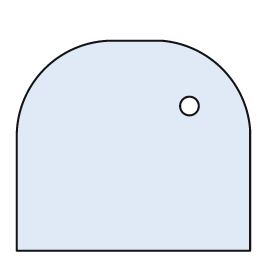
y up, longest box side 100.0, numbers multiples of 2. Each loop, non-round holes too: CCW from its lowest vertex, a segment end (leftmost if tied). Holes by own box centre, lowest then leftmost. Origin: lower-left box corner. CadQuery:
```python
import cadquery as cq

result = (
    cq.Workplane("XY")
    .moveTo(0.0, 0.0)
    .lineTo(100.0, 0.0)
    .lineTo(100.0, 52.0)
    .threePointArc((88.0, 78.0), (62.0, 90.0))
    .lineTo(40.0, 90.0)
    .threePointArc((12.0, 78.0), (0.0, 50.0))
    .close()
    .moveTo(74.0, 62.0)
    .circle(4.0)
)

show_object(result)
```